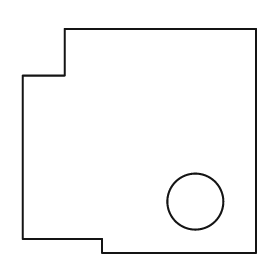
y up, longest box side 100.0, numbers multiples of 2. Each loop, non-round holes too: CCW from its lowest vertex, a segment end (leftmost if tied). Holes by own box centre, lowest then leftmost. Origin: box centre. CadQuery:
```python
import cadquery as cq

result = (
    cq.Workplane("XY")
    .moveTo(-16.0, -48.0)
    .lineTo(50.0, -48.0)
    .lineTo(50.0, 48.0)
    .lineTo(-32.0, 48.0)
    .lineTo(-32.0, 28.0)
    .lineTo(-50.0, 28.0)
    .lineTo(-50.0, -42.0)
    .lineTo(-16.0, -42.0)
    .close()
    .moveTo(24.0, -26.0)
    .circle(12.0)
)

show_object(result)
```